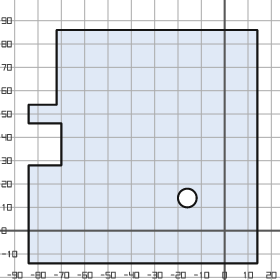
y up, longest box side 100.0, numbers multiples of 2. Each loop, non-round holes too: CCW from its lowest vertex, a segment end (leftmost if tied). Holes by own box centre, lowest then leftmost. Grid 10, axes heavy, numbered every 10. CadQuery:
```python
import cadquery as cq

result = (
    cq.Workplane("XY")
    .moveTo(-84.0, -14.0)
    .lineTo(14.0, -14.0)
    .lineTo(14.0, 86.0)
    .lineTo(-72.0, 86.0)
    .lineTo(-72.0, 54.0)
    .lineTo(-84.0, 54.0)
    .lineTo(-84.0, 46.0)
    .lineTo(-70.0, 46.0)
    .lineTo(-70.0, 28.0)
    .lineTo(-84.0, 28.0)
    .close()
    .moveTo(-16.0, 14.0)
    .circle(4.0)
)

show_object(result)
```